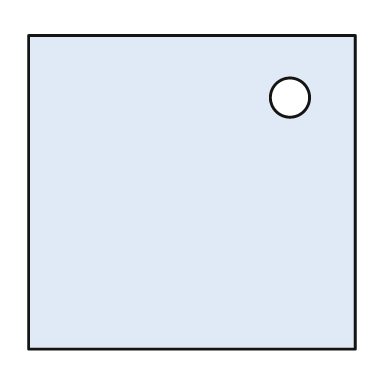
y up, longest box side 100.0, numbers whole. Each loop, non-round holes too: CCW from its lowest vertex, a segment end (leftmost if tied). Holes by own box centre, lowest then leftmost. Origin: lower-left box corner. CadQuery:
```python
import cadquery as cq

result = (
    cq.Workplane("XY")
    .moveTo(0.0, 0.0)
    .lineTo(100.0, 0.0)
    .lineTo(100.0, 96.0)
    .lineTo(0.0, 96.0)
    .close()
    .moveTo(80.0, 77.0)
    .circle(6.0)
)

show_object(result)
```